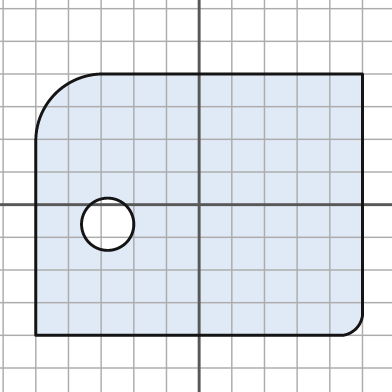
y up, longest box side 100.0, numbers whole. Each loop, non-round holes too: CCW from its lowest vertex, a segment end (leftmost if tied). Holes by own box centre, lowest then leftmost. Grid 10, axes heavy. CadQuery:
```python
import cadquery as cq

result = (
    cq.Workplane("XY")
    .moveTo(-50.0, -40.0)
    .lineTo(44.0, -40.0)
    .threePointArc((48.0, -38.0), (50.0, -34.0))
    .lineTo(50.0, 40.0)
    .lineTo(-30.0, 40.0)
    .threePointArc((-44.0, 34.0), (-50.0, 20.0))
    .close()
    .moveTo(-28.0, -6.0)
    .circle(8.0)
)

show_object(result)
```